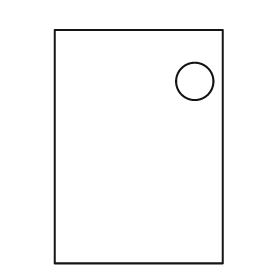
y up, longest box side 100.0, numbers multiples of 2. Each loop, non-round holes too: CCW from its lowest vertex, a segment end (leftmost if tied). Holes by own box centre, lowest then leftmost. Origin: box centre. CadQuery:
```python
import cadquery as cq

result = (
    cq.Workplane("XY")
    .moveTo(-36.0, -50.0)
    .lineTo(36.0, -50.0)
    .lineTo(36.0, 50.0)
    .lineTo(-36.0, 50.0)
    .close()
    .moveTo(24.0, 28.0)
    .circle(8.0)
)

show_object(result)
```